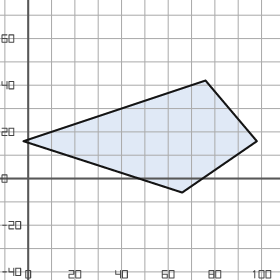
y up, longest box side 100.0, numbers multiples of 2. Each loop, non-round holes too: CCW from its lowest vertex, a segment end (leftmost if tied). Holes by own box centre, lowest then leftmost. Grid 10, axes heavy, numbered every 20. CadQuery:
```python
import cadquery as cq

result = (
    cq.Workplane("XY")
    .moveTo(66.0, -6.0)
    .lineTo(98.0, 16.0)
    .lineTo(76.0, 42.0)
    .lineTo(-2.0, 16.0)
    .close()
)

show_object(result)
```